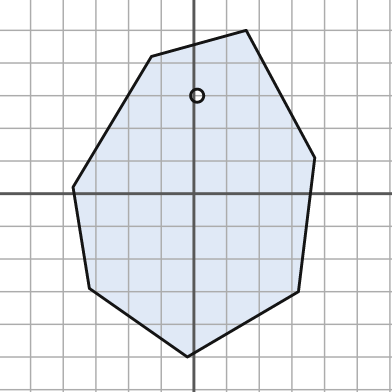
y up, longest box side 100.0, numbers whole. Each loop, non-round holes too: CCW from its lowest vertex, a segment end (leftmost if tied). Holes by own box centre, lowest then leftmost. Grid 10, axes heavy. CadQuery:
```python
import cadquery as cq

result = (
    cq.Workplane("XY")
    .moveTo(-2.0, -50.0)
    .lineTo(32.0, -30.0)
    .lineTo(37.0, 11.0)
    .lineTo(16.0, 50.0)
    .lineTo(-13.0, 42.0)
    .lineTo(-37.0, 2.0)
    .lineTo(-32.0, -29.0)
    .close()
    .moveTo(1.0, 30.0)
    .circle(2.0)
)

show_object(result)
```